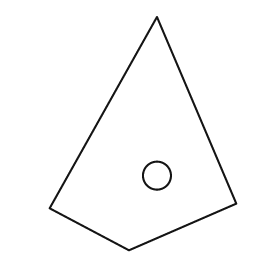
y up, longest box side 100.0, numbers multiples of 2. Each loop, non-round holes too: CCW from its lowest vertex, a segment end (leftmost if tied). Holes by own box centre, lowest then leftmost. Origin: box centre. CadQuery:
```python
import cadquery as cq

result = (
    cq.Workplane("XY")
    .moveTo(-6.0, -50.0)
    .lineTo(40.0, -30.0)
    .lineTo(6.0, 50.0)
    .lineTo(-40.0, -32.0)
    .close()
    .moveTo(6.0, -18.0)
    .circle(6.0)
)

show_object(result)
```